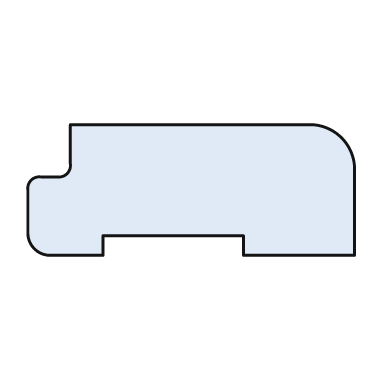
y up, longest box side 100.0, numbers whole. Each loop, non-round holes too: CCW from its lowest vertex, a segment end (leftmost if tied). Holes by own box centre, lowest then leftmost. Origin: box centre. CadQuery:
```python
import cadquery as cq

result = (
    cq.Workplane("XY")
    .moveTo(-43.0, -20.0)
    .lineTo(-27.0, -20.0)
    .lineTo(-27.0, -14.0)
    .lineTo(16.0, -14.0)
    .lineTo(16.0, -20.0)
    .lineTo(50.0, -20.0)
    .lineTo(50.0, 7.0)
    .threePointArc((46.0, 16.0), (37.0, 20.0))
    .lineTo(-37.0, 20.0)
    .lineTo(-37.0, 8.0)
    .threePointArc((-38.0, 5.0), (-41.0, 4.0))
    .lineTo(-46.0, 4.0)
    .threePointArc((-49.0, 3.0), (-50.0, 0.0))
    .lineTo(-50.0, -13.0)
    .threePointArc((-48.0, -18.0), (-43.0, -20.0))
    .close()
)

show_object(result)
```